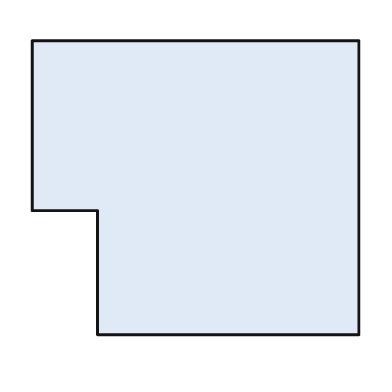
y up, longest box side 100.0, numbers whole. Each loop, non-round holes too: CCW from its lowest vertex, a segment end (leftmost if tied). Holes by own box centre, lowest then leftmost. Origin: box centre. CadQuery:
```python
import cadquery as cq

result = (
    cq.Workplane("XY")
    .moveTo(-30.0, -45.0)
    .lineTo(50.0, -45.0)
    .lineTo(50.0, 45.0)
    .lineTo(-50.0, 45.0)
    .lineTo(-50.0, -7.0)
    .lineTo(-30.0, -7.0)
    .close()
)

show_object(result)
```